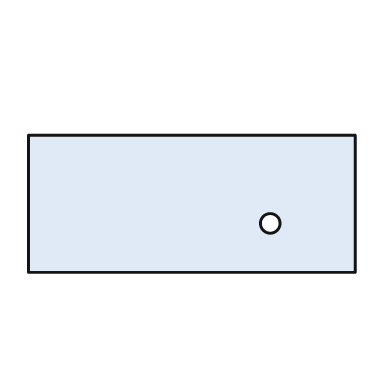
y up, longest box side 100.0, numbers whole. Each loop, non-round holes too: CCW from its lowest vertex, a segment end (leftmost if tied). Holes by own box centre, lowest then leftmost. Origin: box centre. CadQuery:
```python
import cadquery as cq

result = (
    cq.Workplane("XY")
    .moveTo(-50.0, -21.0)
    .lineTo(50.0, -21.0)
    .lineTo(50.0, 21.0)
    .lineTo(-50.0, 21.0)
    .close()
    .moveTo(24.0, -6.0)
    .circle(3.0)
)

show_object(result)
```